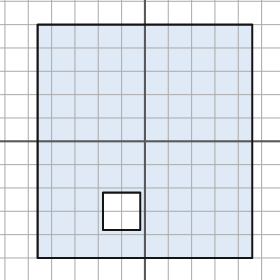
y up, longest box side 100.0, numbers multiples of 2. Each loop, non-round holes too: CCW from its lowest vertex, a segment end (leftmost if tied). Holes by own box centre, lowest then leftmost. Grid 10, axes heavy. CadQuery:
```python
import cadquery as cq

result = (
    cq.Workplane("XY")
    .moveTo(-46.0, -50.0)
    .lineTo(46.0, -50.0)
    .lineTo(46.0, 50.0)
    .lineTo(-46.0, 50.0)
    .close()
    .moveTo(-18.0, -38.0)
    .lineTo(-2.0, -38.0)
    .lineTo(-2.0, -22.0)
    .lineTo(-18.0, -22.0)
    .close()
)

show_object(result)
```